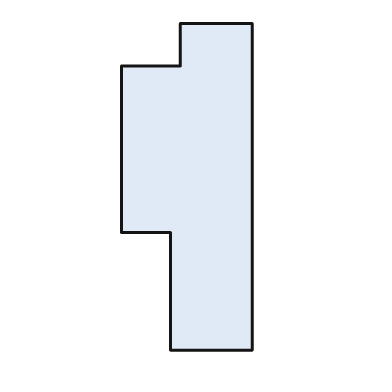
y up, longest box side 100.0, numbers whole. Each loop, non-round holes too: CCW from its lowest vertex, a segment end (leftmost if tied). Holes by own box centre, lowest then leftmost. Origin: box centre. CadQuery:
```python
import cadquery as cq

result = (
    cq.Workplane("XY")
    .moveTo(-5.0, -50.0)
    .lineTo(20.0, -50.0)
    .lineTo(20.0, 50.0)
    .lineTo(-2.0, 50.0)
    .lineTo(-2.0, 37.0)
    .lineTo(-20.0, 37.0)
    .lineTo(-20.0, -14.0)
    .lineTo(-5.0, -14.0)
    .close()
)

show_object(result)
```